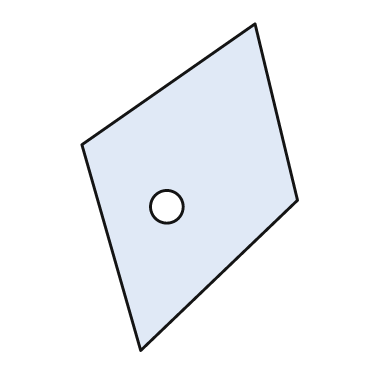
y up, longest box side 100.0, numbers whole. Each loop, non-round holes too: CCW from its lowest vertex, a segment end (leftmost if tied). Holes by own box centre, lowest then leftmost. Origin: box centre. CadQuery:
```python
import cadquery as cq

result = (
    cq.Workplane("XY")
    .moveTo(-15.0, -50.0)
    .lineTo(33.0, -4.0)
    .lineTo(20.0, 50.0)
    .lineTo(-33.0, 13.0)
    .close()
    .moveTo(-7.0, -6.0)
    .circle(5.0)
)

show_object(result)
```